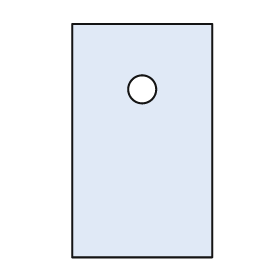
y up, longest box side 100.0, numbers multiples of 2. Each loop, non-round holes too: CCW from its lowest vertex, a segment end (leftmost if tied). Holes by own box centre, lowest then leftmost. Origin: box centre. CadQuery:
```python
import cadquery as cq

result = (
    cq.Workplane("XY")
    .moveTo(-30.0, -50.0)
    .lineTo(30.0, -50.0)
    .lineTo(30.0, 50.0)
    .lineTo(-30.0, 50.0)
    .close()
    .moveTo(0.0, 22.0)
    .circle(6.0)
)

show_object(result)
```